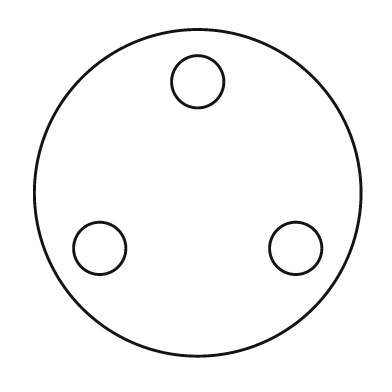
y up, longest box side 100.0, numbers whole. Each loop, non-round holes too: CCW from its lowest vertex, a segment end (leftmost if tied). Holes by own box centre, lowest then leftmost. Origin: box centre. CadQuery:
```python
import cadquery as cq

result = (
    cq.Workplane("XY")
    .moveTo(0.0, 0.0)
    .circle(50.0)
    .moveTo(-30.0, -17.0)
    .circle(8.0)
    .moveTo(30.0, -17.0)
    .circle(8.0)
    .moveTo(0.0, 34.0)
    .circle(8.0)
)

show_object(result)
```